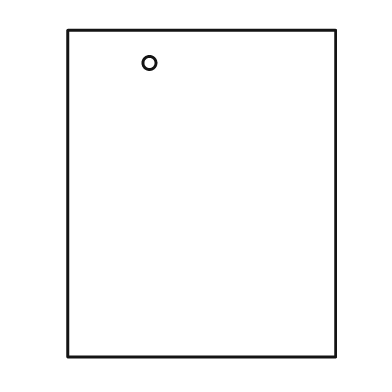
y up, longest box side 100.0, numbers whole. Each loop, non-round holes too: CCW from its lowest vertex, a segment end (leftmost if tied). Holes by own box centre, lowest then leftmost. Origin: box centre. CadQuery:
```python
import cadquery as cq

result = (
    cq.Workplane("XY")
    .moveTo(-41.0, -50.0)
    .lineTo(41.0, -50.0)
    .lineTo(41.0, 50.0)
    .lineTo(-41.0, 50.0)
    .close()
    .moveTo(-16.0, 40.0)
    .circle(2.0)
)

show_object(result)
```